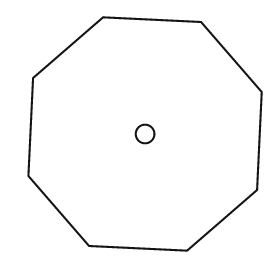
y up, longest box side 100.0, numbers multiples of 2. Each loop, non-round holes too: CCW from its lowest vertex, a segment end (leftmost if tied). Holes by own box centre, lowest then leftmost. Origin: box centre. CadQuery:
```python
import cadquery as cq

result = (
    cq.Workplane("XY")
    .moveTo(18.0, -50.0)
    .lineTo(48.0, -24.0)
    .lineTo(50.0, 18.0)
    .lineTo(24.0, 48.0)
    .lineTo(-18.0, 50.0)
    .lineTo(-48.0, 24.0)
    .lineTo(-50.0, -18.0)
    .lineTo(-24.0, -48.0)
    .close()
    .moveTo(0.0, 0.0)
    .circle(4.0)
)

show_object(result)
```